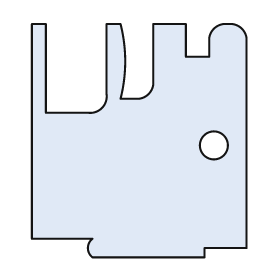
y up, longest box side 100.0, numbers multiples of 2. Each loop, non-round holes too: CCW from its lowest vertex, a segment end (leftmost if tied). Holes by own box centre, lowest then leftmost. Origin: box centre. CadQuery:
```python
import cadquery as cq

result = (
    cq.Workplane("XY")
    .moveTo(-20.0, -50.0)
    .lineTo(28.0, -50.0)
    .lineTo(28.0, -46.0)
    .lineTo(46.0, -46.0)
    .lineTo(46.0, 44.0)
    .threePointArc((44.0, 48.0), (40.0, 50.0))
    .lineTo(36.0, 50.0)
    .threePointArc((32.0, 48.0), (30.0, 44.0))
    .lineTo(30.0, 36.0)
    .lineTo(20.0, 36.0)
    .lineTo(20.0, 50.0)
    .lineTo(6.0, 50.0)
    .lineTo(6.0, 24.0)
    .threePointArc((4.0, 20.0), (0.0, 18.0))
    .lineTo(-8.0, 18.0)
    .threePointArc((-6.0, 34.0), (-8.0, 50.0))
    .lineTo(-14.0, 50.0)
    .lineTo(-14.0, 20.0)
    .threePointArc((-16.0, 14.0), (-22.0, 12.0))
    .lineTo(-40.0, 12.0)
    .lineTo(-40.0, 50.0)
    .lineTo(-46.0, 50.0)
    .lineTo(-46.0, -42.0)
    .lineTo(-20.0, -42.0)
    .threePointArc((-22.0, -46.0), (-20.0, -50.0))
    .close()
    .moveTo(32.0, -2.0)
    .circle(6.0)
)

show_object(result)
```